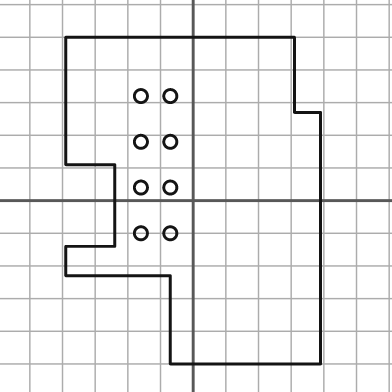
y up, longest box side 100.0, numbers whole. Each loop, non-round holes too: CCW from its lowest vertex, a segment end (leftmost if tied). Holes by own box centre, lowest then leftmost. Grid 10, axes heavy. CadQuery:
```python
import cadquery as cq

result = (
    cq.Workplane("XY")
    .moveTo(-7.0, -50.0)
    .lineTo(39.0, -50.0)
    .lineTo(39.0, 27.0)
    .lineTo(31.0, 27.0)
    .lineTo(31.0, 50.0)
    .lineTo(-39.0, 50.0)
    .lineTo(-39.0, 11.0)
    .lineTo(-24.0, 11.0)
    .lineTo(-24.0, -14.0)
    .lineTo(-39.0, -14.0)
    .lineTo(-39.0, -23.0)
    .lineTo(-7.0, -23.0)
    .close()
    .moveTo(-16.0, -10.0)
    .circle(2.0)
    .moveTo(-7.0, -10.0)
    .circle(2.0)
    .moveTo(-16.0, 4.0)
    .circle(2.0)
    .moveTo(-7.0, 4.0)
    .circle(2.0)
    .moveTo(-16.0, 18.0)
    .circle(2.0)
    .moveTo(-7.0, 18.0)
    .circle(2.0)
    .moveTo(-16.0, 32.0)
    .circle(2.0)
    .moveTo(-7.0, 32.0)
    .circle(2.0)
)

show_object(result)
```